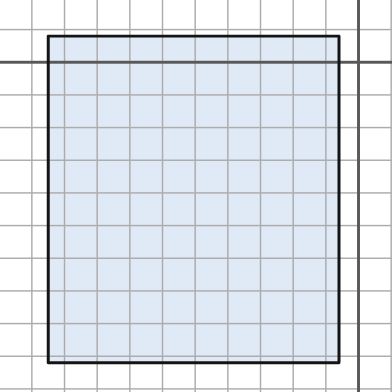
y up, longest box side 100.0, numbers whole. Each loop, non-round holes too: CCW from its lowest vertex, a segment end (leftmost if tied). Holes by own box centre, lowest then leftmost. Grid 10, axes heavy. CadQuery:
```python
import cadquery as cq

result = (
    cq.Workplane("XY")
    .moveTo(-95.0, -92.0)
    .lineTo(-6.0, -92.0)
    .lineTo(-6.0, 8.0)
    .lineTo(-95.0, 8.0)
    .close()
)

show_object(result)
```